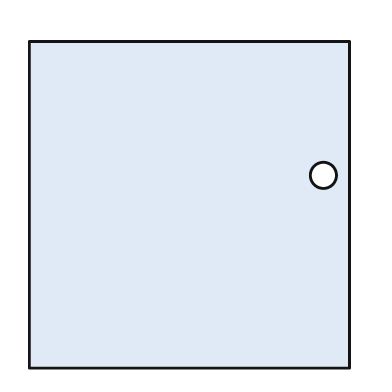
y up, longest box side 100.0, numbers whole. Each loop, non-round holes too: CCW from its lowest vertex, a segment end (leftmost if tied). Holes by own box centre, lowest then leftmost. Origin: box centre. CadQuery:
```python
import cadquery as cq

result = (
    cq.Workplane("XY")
    .moveTo(-49.0, -50.0)
    .lineTo(49.0, -50.0)
    .lineTo(49.0, 50.0)
    .lineTo(-49.0, 50.0)
    .close()
    .moveTo(41.0, 9.0)
    .circle(4.0)
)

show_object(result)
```